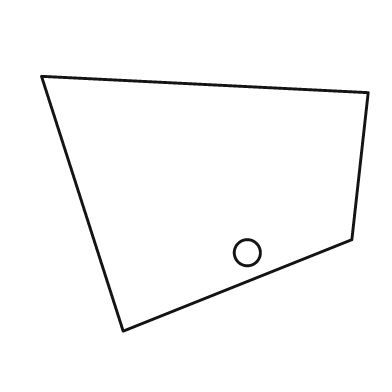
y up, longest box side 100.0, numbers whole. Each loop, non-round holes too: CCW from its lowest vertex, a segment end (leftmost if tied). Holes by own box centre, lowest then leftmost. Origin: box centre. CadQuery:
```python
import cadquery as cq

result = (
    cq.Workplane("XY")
    .moveTo(-25.0, -39.0)
    .lineTo(45.0, -11.0)
    .lineTo(50.0, 34.0)
    .lineTo(-50.0, 39.0)
    .close()
    .moveTo(13.0, -15.0)
    .circle(4.0)
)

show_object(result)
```